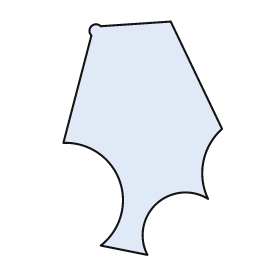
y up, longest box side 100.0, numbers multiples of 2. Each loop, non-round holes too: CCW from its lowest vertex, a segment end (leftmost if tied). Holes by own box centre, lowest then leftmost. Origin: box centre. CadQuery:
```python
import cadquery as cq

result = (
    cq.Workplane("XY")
    .moveTo(2.0, -50.0)
    .threePointArc((6.0, -28.0), (28.0, -26.0))
    .threePointArc((26.0, -10.0), (34.0, 4.0))
    .lineTo(12.0, 50.0)
    .lineTo(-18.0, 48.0)
    .threePointArc((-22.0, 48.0), (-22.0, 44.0))
    .lineTo(-34.0, -2.0)
    .threePointArc((-10.0, -18.0), (-18.0, -46.0))
    .close()
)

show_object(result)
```